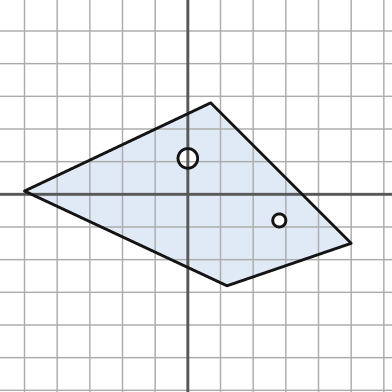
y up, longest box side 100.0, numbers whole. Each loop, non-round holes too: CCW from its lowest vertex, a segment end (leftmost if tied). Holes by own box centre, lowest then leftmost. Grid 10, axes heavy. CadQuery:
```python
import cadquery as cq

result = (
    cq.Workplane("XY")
    .moveTo(12.0, -28.0)
    .lineTo(50.0, -15.0)
    .lineTo(7.0, 28.0)
    .lineTo(-50.0, 1.0)
    .close()
    .moveTo(28.0, -8.0)
    .circle(2.0)
    .moveTo(0.0, 11.0)
    .circle(3.0)
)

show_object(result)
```